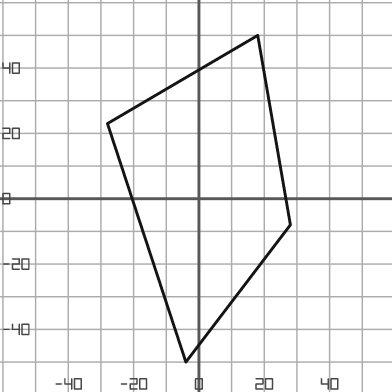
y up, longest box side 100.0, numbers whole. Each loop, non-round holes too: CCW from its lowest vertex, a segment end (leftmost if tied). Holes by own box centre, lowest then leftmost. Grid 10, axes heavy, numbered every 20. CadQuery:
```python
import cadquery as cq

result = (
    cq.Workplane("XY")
    .moveTo(-4.0, -50.0)
    .lineTo(28.0, -8.0)
    .lineTo(18.0, 50.0)
    .lineTo(-28.0, 23.0)
    .close()
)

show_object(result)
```